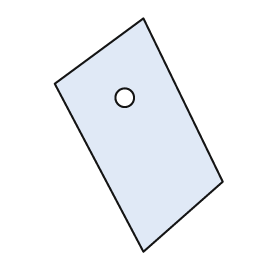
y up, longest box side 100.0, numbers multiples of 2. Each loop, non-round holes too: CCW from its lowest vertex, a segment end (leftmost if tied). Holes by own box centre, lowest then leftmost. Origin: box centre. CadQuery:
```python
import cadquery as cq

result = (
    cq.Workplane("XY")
    .moveTo(2.0, -50.0)
    .lineTo(36.0, -20.0)
    .lineTo(2.0, 50.0)
    .lineTo(-36.0, 22.0)
    .close()
    .moveTo(-6.0, 16.0)
    .circle(4.0)
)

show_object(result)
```